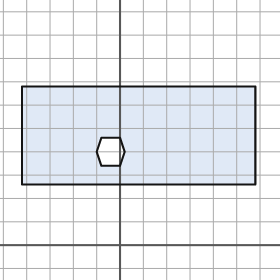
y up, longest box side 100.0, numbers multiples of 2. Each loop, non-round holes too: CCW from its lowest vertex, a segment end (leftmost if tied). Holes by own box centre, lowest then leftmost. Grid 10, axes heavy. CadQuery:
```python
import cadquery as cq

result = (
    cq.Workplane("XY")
    .moveTo(-42.0, 26.0)
    .lineTo(58.0, 26.0)
    .lineTo(58.0, 68.0)
    .lineTo(-42.0, 68.0)
    .close()
    .moveTo(-8.0, 34.0)
    .lineTo(0.0, 34.0)
    .lineTo(2.0, 40.0)
    .lineTo(0.0, 46.0)
    .lineTo(-8.0, 46.0)
    .lineTo(-10.0, 40.0)
    .close()
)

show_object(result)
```